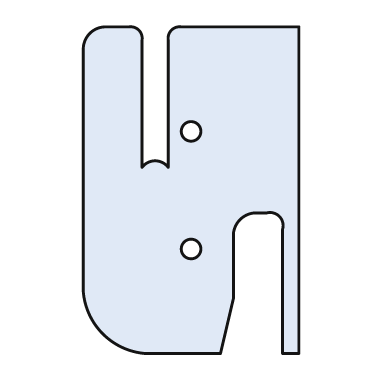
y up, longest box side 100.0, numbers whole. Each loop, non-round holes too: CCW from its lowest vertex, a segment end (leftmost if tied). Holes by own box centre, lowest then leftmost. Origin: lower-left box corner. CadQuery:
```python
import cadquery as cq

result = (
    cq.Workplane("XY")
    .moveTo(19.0, 0.0)
    .lineTo(42.0, 0.0)
    .lineTo(46.0, 17.0)
    .lineTo(46.0, 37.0)
    .threePointArc((48.0, 41.0), (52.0, 43.0))
    .lineTo(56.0, 43.0)
    .threePointArc((60.0, 42.0), (61.0, 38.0))
    .lineTo(61.0, 0.0)
    .lineTo(66.0, 0.0)
    .lineTo(66.0, 100.0)
    .lineTo(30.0, 100.0)
    .threePointArc((27.0, 99.0), (26.0, 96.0))
    .lineTo(26.0, 57.0)
    .threePointArc((22.0, 59.0), (18.0, 57.0))
    .lineTo(18.0, 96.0)
    .threePointArc((17.0, 99.0), (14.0, 100.0))
    .lineTo(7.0, 100.0)
    .threePointArc((2.0, 98.0), (0.0, 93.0))
    .lineTo(0.0, 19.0)
    .threePointArc((6.0, 6.0), (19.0, 0.0))
    .close()
    .moveTo(33.0, 32.0)
    .circle(3.0)
    .moveTo(33.0, 68.0)
    .circle(3.0)
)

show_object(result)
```